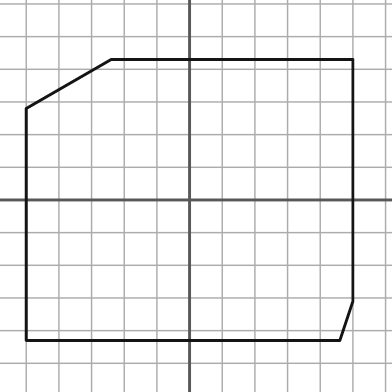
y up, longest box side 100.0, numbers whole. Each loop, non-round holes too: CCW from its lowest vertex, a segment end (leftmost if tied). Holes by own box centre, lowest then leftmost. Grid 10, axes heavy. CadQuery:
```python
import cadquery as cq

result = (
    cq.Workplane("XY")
    .moveTo(-50.0, -43.0)
    .lineTo(46.0, -43.0)
    .lineTo(50.0, -31.0)
    .lineTo(50.0, 43.0)
    .lineTo(-24.0, 43.0)
    .lineTo(-50.0, 28.0)
    .close()
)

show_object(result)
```